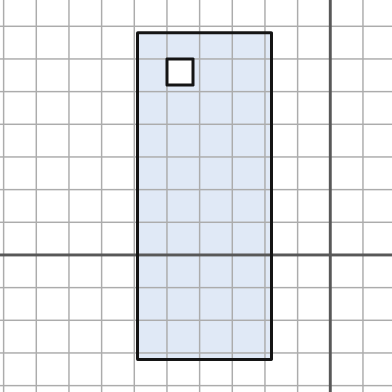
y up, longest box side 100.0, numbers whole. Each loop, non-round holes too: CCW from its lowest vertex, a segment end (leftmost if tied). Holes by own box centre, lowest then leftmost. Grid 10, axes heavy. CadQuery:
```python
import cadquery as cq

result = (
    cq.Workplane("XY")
    .moveTo(-59.0, -32.0)
    .lineTo(-18.0, -32.0)
    .lineTo(-18.0, 68.0)
    .lineTo(-59.0, 68.0)
    .close()
    .moveTo(-50.0, 52.0)
    .lineTo(-42.0, 52.0)
    .lineTo(-42.0, 60.0)
    .lineTo(-50.0, 60.0)
    .close()
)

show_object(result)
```